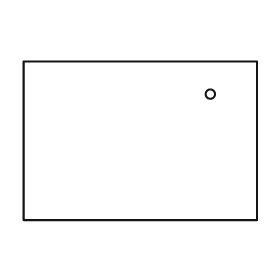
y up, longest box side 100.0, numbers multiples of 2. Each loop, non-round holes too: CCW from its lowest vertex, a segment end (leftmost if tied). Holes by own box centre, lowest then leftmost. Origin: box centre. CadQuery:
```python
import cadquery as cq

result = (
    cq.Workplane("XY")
    .moveTo(-50.0, -34.0)
    .lineTo(50.0, -34.0)
    .lineTo(50.0, 34.0)
    .lineTo(-50.0, 34.0)
    .close()
    .moveTo(30.0, 20.0)
    .circle(2.0)
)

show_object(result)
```